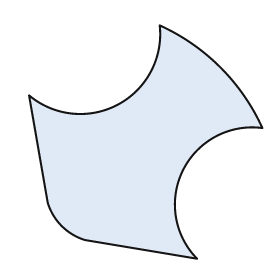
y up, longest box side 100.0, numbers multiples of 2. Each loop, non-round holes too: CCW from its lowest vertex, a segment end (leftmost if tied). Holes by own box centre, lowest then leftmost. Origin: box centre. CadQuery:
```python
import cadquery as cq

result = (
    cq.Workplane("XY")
    .moveTo(22.0, -50.0)
    .threePointArc((16.0, -12.0), (50.0, 6.0))
    .threePointArc((32.0, 32.0), (6.0, 50.0))
    .threePointArc((-12.0, 16.0), (-50.0, 20.0))
    .lineTo(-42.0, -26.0)
    .threePointArc((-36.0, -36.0), (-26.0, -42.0))
    .close()
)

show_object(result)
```